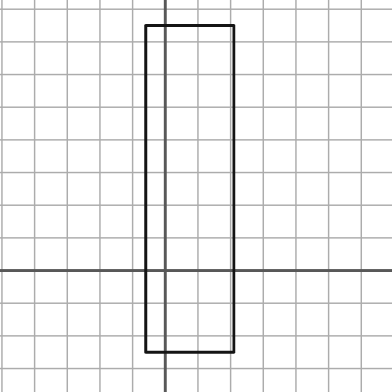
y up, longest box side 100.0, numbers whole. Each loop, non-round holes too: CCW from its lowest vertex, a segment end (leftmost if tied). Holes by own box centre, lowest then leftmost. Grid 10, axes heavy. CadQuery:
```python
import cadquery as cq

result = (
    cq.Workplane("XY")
    .moveTo(-6.0, -25.0)
    .lineTo(21.0, -25.0)
    .lineTo(21.0, 75.0)
    .lineTo(-6.0, 75.0)
    .close()
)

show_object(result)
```